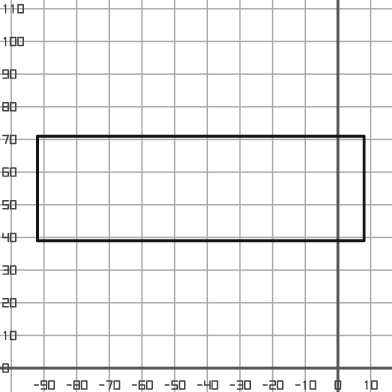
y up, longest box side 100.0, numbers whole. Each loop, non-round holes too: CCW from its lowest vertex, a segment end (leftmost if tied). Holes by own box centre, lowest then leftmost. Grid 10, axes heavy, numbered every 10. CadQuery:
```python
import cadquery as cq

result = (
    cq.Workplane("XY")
    .moveTo(-92.0, 39.0)
    .lineTo(8.0, 39.0)
    .lineTo(8.0, 71.0)
    .lineTo(-92.0, 71.0)
    .close()
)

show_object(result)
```